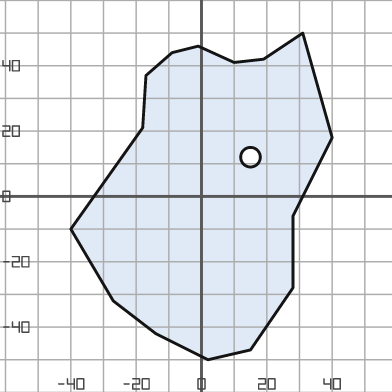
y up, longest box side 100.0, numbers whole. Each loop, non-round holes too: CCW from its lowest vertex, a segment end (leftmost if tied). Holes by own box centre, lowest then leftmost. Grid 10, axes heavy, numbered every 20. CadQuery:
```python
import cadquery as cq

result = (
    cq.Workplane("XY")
    .moveTo(2.0, -50.0)
    .lineTo(15.0, -47.0)
    .lineTo(28.0, -28.0)
    .lineTo(28.0, -6.0)
    .lineTo(40.0, 18.0)
    .lineTo(31.0, 50.0)
    .lineTo(19.0, 42.0)
    .lineTo(10.0, 41.0)
    .lineTo(-1.0, 46.0)
    .lineTo(-9.0, 44.0)
    .lineTo(-17.0, 37.0)
    .lineTo(-18.0, 21.0)
    .lineTo(-40.0, -10.0)
    .lineTo(-27.0, -32.0)
    .lineTo(-14.0, -42.0)
    .close()
    .moveTo(15.0, 12.0)
    .circle(3.0)
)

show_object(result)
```